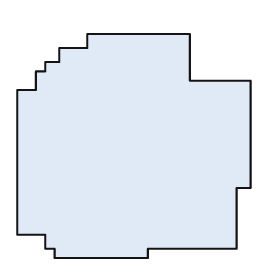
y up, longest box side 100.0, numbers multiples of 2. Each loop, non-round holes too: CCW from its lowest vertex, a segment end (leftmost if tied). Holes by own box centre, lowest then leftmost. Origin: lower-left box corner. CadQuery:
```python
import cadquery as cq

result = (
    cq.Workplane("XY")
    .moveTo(16.0, 0.0)
    .lineTo(56.0, 0.0)
    .lineTo(56.0, 4.0)
    .lineTo(94.0, 4.0)
    .lineTo(94.0, 30.0)
    .lineTo(100.0, 30.0)
    .lineTo(100.0, 76.0)
    .lineTo(74.0, 76.0)
    .lineTo(74.0, 96.0)
    .lineTo(30.0, 96.0)
    .lineTo(30.0, 90.0)
    .lineTo(18.0, 90.0)
    .lineTo(18.0, 84.0)
    .lineTo(12.0, 84.0)
    .lineTo(12.0, 80.0)
    .lineTo(8.0, 80.0)
    .lineTo(8.0, 72.0)
    .lineTo(0.0, 72.0)
    .lineTo(0.0, 10.0)
    .lineTo(12.0, 10.0)
    .lineTo(12.0, 4.0)
    .lineTo(16.0, 4.0)
    .close()
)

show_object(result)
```